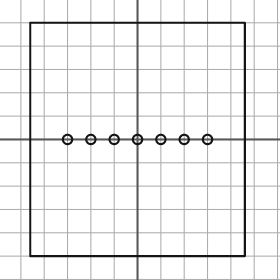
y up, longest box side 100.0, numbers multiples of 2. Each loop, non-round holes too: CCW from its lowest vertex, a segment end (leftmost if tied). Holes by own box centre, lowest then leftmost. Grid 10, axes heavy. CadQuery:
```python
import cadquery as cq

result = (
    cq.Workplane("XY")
    .moveTo(-46.0, -50.0)
    .lineTo(46.0, -50.0)
    .lineTo(46.0, 50.0)
    .lineTo(-46.0, 50.0)
    .close()
    .moveTo(-30.0, 0.0)
    .circle(2.0)
    .moveTo(-20.0, 0.0)
    .circle(2.0)
    .moveTo(-10.0, 0.0)
    .circle(2.0)
    .moveTo(0.0, 0.0)
    .circle(2.0)
    .moveTo(10.0, 0.0)
    .circle(2.0)
    .moveTo(20.0, 0.0)
    .circle(2.0)
    .moveTo(30.0, 0.0)
    .circle(2.0)
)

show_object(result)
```